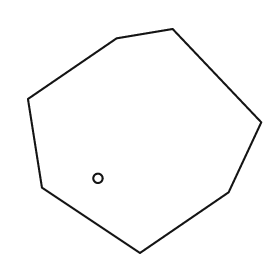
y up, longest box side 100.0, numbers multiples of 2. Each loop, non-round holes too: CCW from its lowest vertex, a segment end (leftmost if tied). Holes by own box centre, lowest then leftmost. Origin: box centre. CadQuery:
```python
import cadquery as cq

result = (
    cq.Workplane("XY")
    .moveTo(-2.0, -48.0)
    .lineTo(36.0, -22.0)
    .lineTo(50.0, 8.0)
    .lineTo(12.0, 48.0)
    .lineTo(-12.0, 44.0)
    .lineTo(-50.0, 18.0)
    .lineTo(-44.0, -20.0)
    .close()
    .moveTo(-20.0, -16.0)
    .circle(2.0)
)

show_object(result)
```